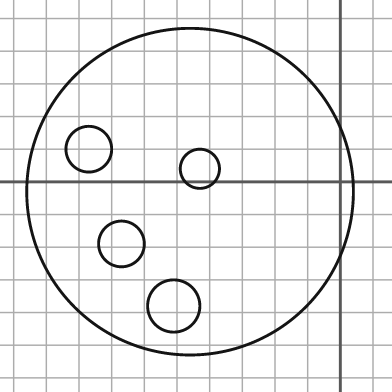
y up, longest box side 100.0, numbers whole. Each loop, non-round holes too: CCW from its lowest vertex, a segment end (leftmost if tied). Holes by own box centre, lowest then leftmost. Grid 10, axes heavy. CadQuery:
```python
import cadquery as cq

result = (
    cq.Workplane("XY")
    .moveTo(-46.0, -3.0)
    .circle(50.0)
    .moveTo(-51.0, -38.0)
    .circle(8.0)
    .moveTo(-67.0, -19.0)
    .circle(7.0)
    .moveTo(-43.0, 4.0)
    .circle(6.0)
    .moveTo(-77.0, 10.0)
    .circle(7.0)
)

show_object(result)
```